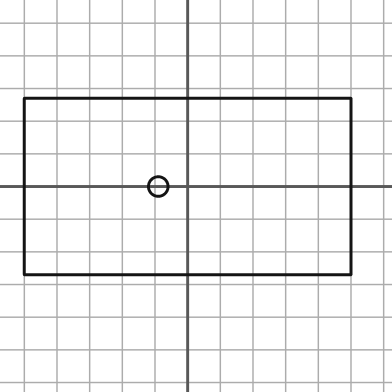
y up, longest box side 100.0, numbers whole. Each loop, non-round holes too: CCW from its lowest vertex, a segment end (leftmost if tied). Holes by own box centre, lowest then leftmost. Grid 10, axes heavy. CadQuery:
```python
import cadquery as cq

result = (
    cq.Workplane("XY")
    .moveTo(-50.0, -27.0)
    .lineTo(50.0, -27.0)
    .lineTo(50.0, 27.0)
    .lineTo(-50.0, 27.0)
    .close()
    .moveTo(-9.0, 0.0)
    .circle(3.0)
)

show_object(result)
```